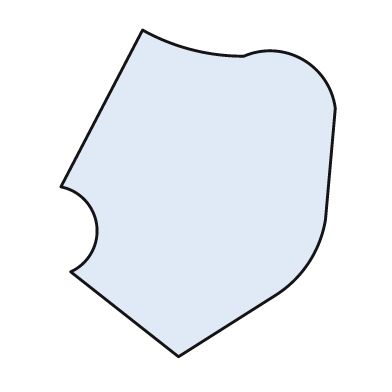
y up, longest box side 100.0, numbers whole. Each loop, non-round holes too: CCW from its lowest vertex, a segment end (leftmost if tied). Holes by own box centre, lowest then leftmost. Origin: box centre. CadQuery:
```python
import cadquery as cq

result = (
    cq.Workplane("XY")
    .moveTo(-6.0, -50.0)
    .lineTo(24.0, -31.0)
    .threePointArc((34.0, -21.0), (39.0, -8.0))
    .lineTo(42.0, 26.0)
    .threePointArc((32.0, 41.0), (14.0, 42.0))
    .threePointArc((-2.0, 44.0), (-17.0, 50.0))
    .lineTo(-42.0, 2.0)
    .threePointArc((-31.0, -10.0), (-39.0, -24.0))
    .close()
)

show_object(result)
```